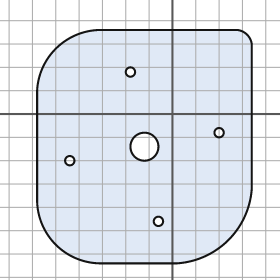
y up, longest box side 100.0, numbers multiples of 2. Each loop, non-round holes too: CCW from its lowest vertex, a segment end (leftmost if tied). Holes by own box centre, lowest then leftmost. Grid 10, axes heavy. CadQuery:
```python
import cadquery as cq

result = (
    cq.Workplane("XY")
    .moveTo(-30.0, -64.0)
    .lineTo(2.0, -64.0)
    .threePointArc((24.0, -54.0), (34.0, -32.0))
    .lineTo(34.0, 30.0)
    .threePointArc((32.0, 34.0), (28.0, 36.0))
    .lineTo(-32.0, 36.0)
    .threePointArc((-50.0, 28.0), (-58.0, 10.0))
    .lineTo(-58.0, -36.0)
    .threePointArc((-50.0, -56.0), (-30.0, -64.0))
    .close()
    .moveTo(-6.0, -46.0)
    .circle(2.0)
    .moveTo(-44.0, -20.0)
    .circle(2.0)
    .moveTo(-12.0, -14.0)
    .circle(6.0)
    .moveTo(20.0, -8.0)
    .circle(2.0)
    .moveTo(-18.0, 18.0)
    .circle(2.0)
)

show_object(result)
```